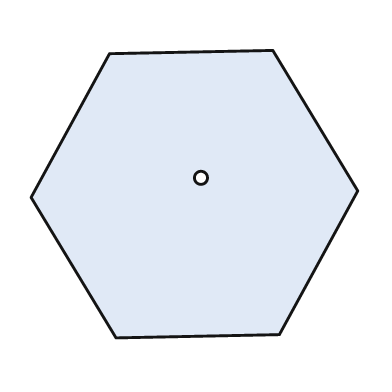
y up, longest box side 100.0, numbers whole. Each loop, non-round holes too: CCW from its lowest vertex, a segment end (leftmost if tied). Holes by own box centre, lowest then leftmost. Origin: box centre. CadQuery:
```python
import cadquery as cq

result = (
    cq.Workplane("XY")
    .moveTo(-24.0, -44.0)
    .lineTo(26.0, -43.0)
    .lineTo(50.0, 1.0)
    .lineTo(24.0, 44.0)
    .lineTo(-26.0, 43.0)
    .lineTo(-50.0, -1.0)
    .close()
    .moveTo(2.0, 5.0)
    .circle(2.0)
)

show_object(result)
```